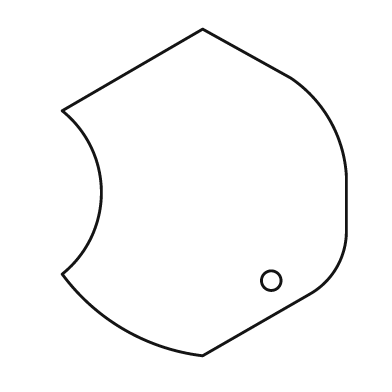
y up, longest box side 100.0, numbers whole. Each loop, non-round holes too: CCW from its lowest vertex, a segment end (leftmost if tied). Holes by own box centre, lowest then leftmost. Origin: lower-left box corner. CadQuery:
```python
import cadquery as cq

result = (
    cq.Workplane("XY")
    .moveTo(43.0, 0.0)
    .lineTo(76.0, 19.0)
    .threePointArc((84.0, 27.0), (87.0, 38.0))
    .lineTo(87.0, 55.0)
    .threePointArc((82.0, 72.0), (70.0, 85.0))
    .lineTo(43.0, 100.0)
    .lineTo(0.0, 75.0)
    .threePointArc((12.0, 50.0), (0.0, 25.0))
    .threePointArc((19.0, 8.0), (43.0, 0.0))
    .close()
    .moveTo(64.0, 23.0)
    .circle(3.0)
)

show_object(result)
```